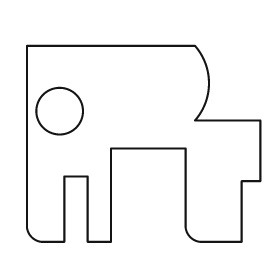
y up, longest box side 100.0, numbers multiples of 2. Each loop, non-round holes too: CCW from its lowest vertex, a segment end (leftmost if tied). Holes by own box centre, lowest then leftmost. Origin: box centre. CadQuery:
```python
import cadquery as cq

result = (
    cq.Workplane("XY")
    .moveTo(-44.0, -42.0)
    .lineTo(-34.0, -42.0)
    .lineTo(-34.0, -14.0)
    .lineTo(-24.0, -14.0)
    .lineTo(-24.0, -42.0)
    .lineTo(-14.0, -42.0)
    .lineTo(-14.0, -2.0)
    .lineTo(18.0, -2.0)
    .lineTo(18.0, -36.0)
    .threePointArc((20.0, -40.0), (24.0, -42.0))
    .lineTo(42.0, -42.0)
    .lineTo(42.0, -16.0)
    .lineTo(50.0, -16.0)
    .lineTo(50.0, 10.0)
    .lineTo(22.0, 10.0)
    .threePointArc((28.0, 26.0), (22.0, 42.0))
    .lineTo(-50.0, 42.0)
    .lineTo(-50.0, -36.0)
    .threePointArc((-48.0, -40.0), (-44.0, -42.0))
    .close()
    .moveTo(-36.0, 14.0)
    .circle(10.0)
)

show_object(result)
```